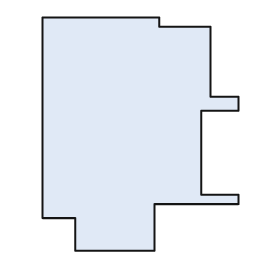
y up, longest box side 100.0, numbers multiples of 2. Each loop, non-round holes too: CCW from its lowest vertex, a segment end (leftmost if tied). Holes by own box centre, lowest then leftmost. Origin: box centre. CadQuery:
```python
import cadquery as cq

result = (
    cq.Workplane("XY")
    .moveTo(-28.0, -50.0)
    .lineTo(6.0, -50.0)
    .lineTo(6.0, -30.0)
    .lineTo(42.0, -30.0)
    .lineTo(42.0, -26.0)
    .lineTo(26.0, -26.0)
    .lineTo(26.0, 10.0)
    .lineTo(42.0, 10.0)
    .lineTo(42.0, 16.0)
    .lineTo(30.0, 16.0)
    .lineTo(30.0, 46.0)
    .lineTo(8.0, 46.0)
    .lineTo(8.0, 50.0)
    .lineTo(-42.0, 50.0)
    .lineTo(-42.0, -36.0)
    .lineTo(-28.0, -36.0)
    .close()
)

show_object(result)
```